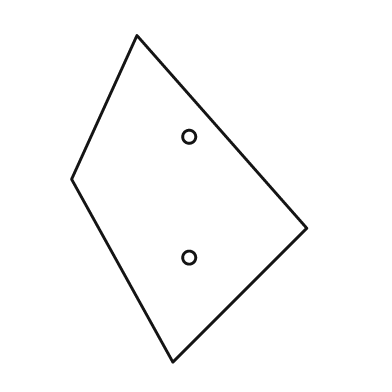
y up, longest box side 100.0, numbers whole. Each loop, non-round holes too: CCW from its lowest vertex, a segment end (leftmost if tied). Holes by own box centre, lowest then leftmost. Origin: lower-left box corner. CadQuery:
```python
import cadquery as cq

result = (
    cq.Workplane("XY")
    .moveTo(31.0, 0.0)
    .lineTo(72.0, 41.0)
    .lineTo(20.0, 100.0)
    .lineTo(0.0, 56.0)
    .close()
    .moveTo(36.0, 32.0)
    .circle(2.0)
    .moveTo(36.0, 69.0)
    .circle(2.0)
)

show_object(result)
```